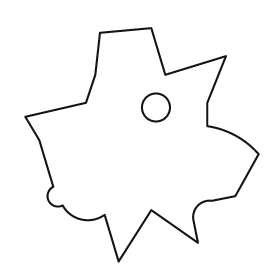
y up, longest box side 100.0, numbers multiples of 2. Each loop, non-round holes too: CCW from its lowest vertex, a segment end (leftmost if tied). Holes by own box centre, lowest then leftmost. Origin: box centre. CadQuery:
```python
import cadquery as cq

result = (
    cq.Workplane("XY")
    .moveTo(-10.0, -50.0)
    .lineTo(4.0, -28.0)
    .lineTo(24.0, -42.0)
    .lineTo(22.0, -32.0)
    .threePointArc((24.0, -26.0), (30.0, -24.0))
    .lineTo(40.0, -22.0)
    .lineTo(50.0, -4.0)
    .threePointArc((40.0, 4.0), (28.0, 8.0))
    .lineTo(28.0, 18.0)
    .lineTo(36.0, 38.0)
    .lineTo(10.0, 30.0)
    .lineTo(4.0, 50.0)
    .lineTo(-18.0, 48.0)
    .lineTo(-20.0, 30.0)
    .lineTo(-24.0, 18.0)
    .lineTo(-50.0, 12.0)
    .lineTo(-44.0, 2.0)
    .lineTo(-38.0, -18.0)
    .threePointArc((-40.0, -24.0), (-34.0, -26.0))
    .threePointArc((-26.0, -32.0), (-16.0, -30.0))
    .close()
    .moveTo(6.0, 16.0)
    .circle(6.0)
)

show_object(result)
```